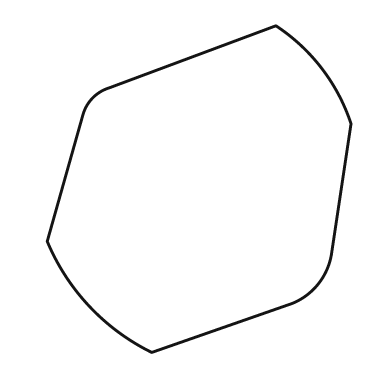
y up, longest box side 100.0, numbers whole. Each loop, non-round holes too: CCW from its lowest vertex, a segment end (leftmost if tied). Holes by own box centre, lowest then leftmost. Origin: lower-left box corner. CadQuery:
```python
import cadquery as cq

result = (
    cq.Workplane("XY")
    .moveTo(32.0, 0.0)
    .lineTo(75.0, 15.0)
    .threePointArc((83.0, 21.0), (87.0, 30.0))
    .lineTo(93.0, 70.0)
    .threePointArc((84.0, 87.0), (70.0, 100.0))
    .lineTo(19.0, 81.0)
    .threePointArc((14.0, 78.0), (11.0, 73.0))
    .lineTo(0.0, 34.0)
    .threePointArc((13.0, 14.0), (32.0, 0.0))
    .close()
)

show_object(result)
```